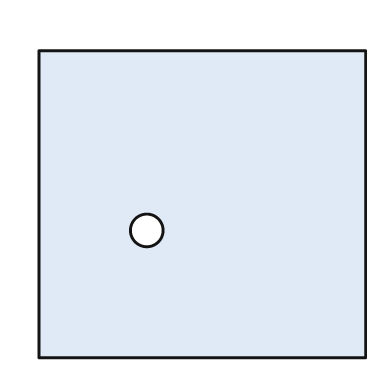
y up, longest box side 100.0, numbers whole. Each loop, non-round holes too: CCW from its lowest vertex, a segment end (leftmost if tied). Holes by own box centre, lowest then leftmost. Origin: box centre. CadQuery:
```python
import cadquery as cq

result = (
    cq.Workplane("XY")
    .moveTo(-50.0, -47.0)
    .lineTo(50.0, -47.0)
    .lineTo(50.0, 47.0)
    .lineTo(-50.0, 47.0)
    .close()
    .moveTo(-17.0, -8.0)
    .circle(5.0)
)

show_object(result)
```